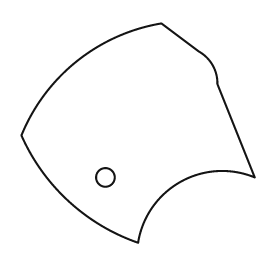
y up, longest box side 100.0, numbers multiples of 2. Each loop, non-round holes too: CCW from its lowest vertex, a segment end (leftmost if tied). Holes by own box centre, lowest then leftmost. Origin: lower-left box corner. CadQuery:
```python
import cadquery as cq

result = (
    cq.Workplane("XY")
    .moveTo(50.0, 0.0)
    .threePointArc((68.0, 26.0), (100.0, 28.0))
    .lineTo(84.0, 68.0)
    .threePointArc((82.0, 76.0), (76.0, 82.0))
    .lineTo(60.0, 94.0)
    .threePointArc((24.0, 78.0), (0.0, 46.0))
    .threePointArc((20.0, 18.0), (50.0, 0.0))
    .close()
    .moveTo(36.0, 28.0)
    .circle(4.0)
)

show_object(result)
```